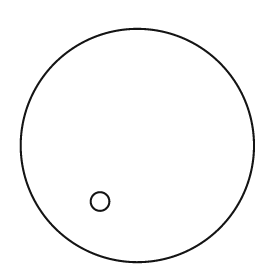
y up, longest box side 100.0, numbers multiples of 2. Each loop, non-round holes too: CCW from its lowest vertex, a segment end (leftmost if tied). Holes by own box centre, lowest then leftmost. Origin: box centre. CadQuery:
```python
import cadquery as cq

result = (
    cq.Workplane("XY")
    .moveTo(0.0, 0.0)
    .circle(50.0)
    .moveTo(-16.0, -24.0)
    .circle(4.0)
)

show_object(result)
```